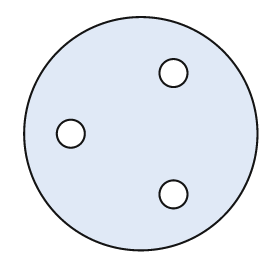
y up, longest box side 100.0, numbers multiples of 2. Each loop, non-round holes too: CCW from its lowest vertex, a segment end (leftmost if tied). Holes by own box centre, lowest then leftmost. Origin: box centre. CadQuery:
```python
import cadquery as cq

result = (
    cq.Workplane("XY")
    .moveTo(0.0, 0.0)
    .circle(50.0)
    .moveTo(14.0, -26.0)
    .circle(6.0)
    .moveTo(-30.0, 0.0)
    .circle(6.0)
    .moveTo(14.0, 26.0)
    .circle(6.0)
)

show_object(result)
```